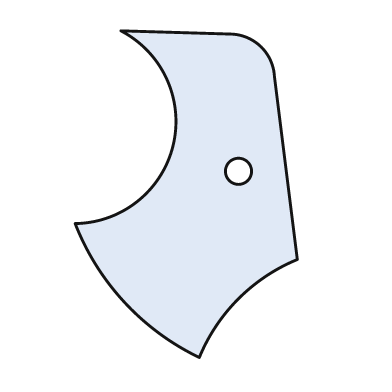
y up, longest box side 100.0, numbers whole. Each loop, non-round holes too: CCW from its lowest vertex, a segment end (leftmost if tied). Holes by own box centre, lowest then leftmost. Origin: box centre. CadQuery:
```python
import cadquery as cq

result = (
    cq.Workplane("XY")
    .moveTo(4.0, -50.0)
    .threePointArc((16.0, -32.0), (34.0, -20.0))
    .lineTo(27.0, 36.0)
    .threePointArc((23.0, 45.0), (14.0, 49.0))
    .lineTo(-20.0, 50.0)
    .threePointArc((-4.0, 15.0), (-34.0, -9.0))
    .threePointArc((-19.0, -33.0), (4.0, -50.0))
    .close()
    .moveTo(16.0, 7.0)
    .circle(4.0)
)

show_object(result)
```